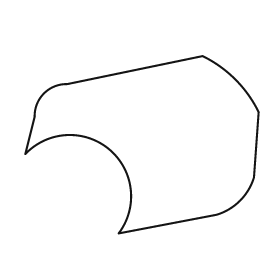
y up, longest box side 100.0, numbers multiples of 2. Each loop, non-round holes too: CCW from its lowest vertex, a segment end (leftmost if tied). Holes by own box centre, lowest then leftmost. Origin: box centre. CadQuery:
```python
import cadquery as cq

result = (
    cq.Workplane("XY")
    .moveTo(-10.0, -38.0)
    .lineTo(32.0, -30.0)
    .threePointArc((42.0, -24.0), (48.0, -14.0))
    .lineTo(50.0, 14.0)
    .threePointArc((40.0, 28.0), (26.0, 38.0))
    .lineTo(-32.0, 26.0)
    .threePointArc((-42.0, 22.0), (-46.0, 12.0))
    .lineTo(-50.0, -4.0)
    .threePointArc((-14.0, -2.0), (-10.0, -38.0))
    .close()
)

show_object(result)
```